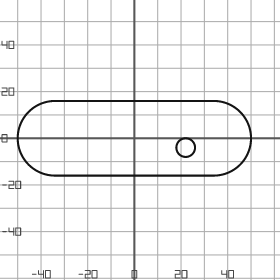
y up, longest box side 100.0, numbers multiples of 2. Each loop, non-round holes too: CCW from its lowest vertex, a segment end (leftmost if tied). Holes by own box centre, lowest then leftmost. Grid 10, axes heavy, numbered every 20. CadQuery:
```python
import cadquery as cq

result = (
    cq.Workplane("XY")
    .moveTo(-34.0, -16.0)
    .lineTo(34.0, -16.0)
    .threePointArc((50.0, 0.0), (34.0, 16.0))
    .lineTo(-34.0, 16.0)
    .threePointArc((-50.0, 0.0), (-34.0, -16.0))
    .close()
    .moveTo(22.0, -4.0)
    .circle(4.0)
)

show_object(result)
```